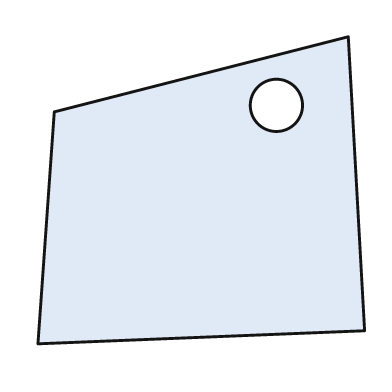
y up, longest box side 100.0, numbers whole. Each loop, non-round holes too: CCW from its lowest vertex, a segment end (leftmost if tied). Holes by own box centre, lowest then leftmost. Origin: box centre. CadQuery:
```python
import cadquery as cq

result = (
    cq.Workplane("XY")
    .moveTo(-50.0, -47.0)
    .lineTo(50.0, -43.0)
    .lineTo(45.0, 47.0)
    .lineTo(-45.0, 24.0)
    .close()
    .moveTo(23.0, 26.0)
    .circle(8.0)
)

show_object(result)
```